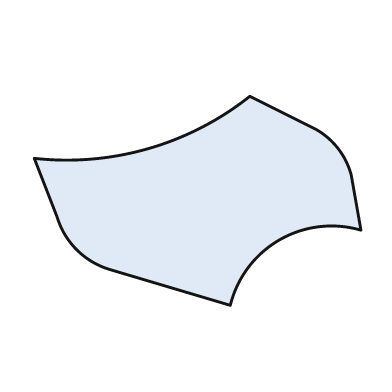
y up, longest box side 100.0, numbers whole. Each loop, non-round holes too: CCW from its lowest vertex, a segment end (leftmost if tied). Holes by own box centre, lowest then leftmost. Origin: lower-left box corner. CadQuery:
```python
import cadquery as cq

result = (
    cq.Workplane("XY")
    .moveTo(60.0, 0.0)
    .threePointArc((75.0, 20.0), (100.0, 23.0))
    .lineTo(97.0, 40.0)
    .threePointArc((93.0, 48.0), (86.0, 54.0))
    .lineTo(66.0, 64.0)
    .threePointArc((35.0, 48.0), (0.0, 45.0))
    .lineTo(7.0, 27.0)
    .threePointArc((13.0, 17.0), (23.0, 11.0))
    .close()
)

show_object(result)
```